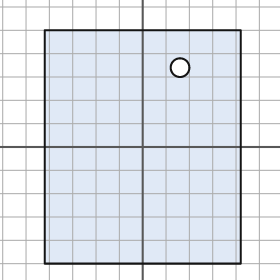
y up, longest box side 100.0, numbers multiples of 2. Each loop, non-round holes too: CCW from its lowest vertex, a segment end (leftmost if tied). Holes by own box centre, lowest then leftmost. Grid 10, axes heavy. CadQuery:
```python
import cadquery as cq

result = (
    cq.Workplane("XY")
    .moveTo(-42.0, -50.0)
    .lineTo(42.0, -50.0)
    .lineTo(42.0, 50.0)
    .lineTo(-42.0, 50.0)
    .close()
    .moveTo(16.0, 34.0)
    .circle(4.0)
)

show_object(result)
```